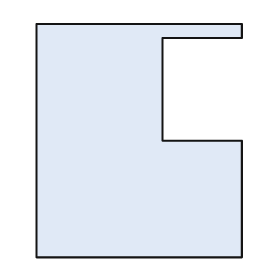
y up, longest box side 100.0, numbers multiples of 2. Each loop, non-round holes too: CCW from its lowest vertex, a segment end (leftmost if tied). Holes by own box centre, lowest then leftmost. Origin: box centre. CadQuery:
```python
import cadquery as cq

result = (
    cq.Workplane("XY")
    .moveTo(-44.0, -50.0)
    .lineTo(44.0, -50.0)
    .lineTo(44.0, 0.0)
    .lineTo(10.0, 0.0)
    .lineTo(10.0, 44.0)
    .lineTo(44.0, 44.0)
    .lineTo(44.0, 50.0)
    .lineTo(-44.0, 50.0)
    .close()
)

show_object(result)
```